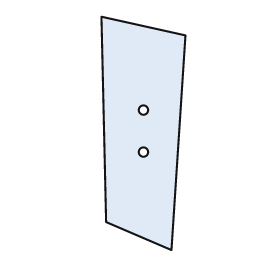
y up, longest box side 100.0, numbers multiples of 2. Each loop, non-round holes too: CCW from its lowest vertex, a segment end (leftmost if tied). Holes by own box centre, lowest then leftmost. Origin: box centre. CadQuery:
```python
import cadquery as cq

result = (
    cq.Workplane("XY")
    .moveTo(12.0, -50.0)
    .lineTo(18.0, 42.0)
    .lineTo(-18.0, 50.0)
    .lineTo(-16.0, -38.0)
    .close()
    .moveTo(0.0, -8.0)
    .circle(2.0)
    .moveTo(0.0, 10.0)
    .circle(2.0)
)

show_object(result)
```